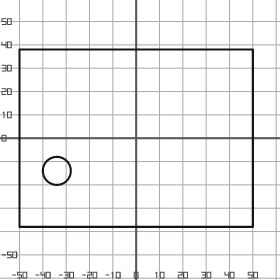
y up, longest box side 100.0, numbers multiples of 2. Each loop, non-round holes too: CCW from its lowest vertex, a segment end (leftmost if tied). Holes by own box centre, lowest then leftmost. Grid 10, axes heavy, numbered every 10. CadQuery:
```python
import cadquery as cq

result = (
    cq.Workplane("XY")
    .moveTo(-50.0, -38.0)
    .lineTo(50.0, -38.0)
    .lineTo(50.0, 38.0)
    .lineTo(-50.0, 38.0)
    .close()
    .moveTo(-34.0, -14.0)
    .circle(6.0)
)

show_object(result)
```